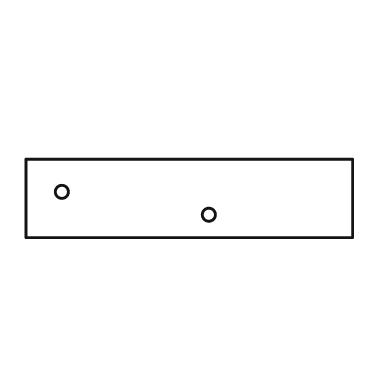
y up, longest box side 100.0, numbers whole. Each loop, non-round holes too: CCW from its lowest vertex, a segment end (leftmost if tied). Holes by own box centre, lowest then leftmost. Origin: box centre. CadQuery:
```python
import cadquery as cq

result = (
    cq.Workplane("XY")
    .moveTo(-50.0, -12.0)
    .lineTo(50.0, -12.0)
    .lineTo(50.0, 12.0)
    .lineTo(-50.0, 12.0)
    .close()
    .moveTo(6.0, -5.0)
    .circle(2.0)
    .moveTo(-39.0, 2.0)
    .circle(2.0)
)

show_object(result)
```